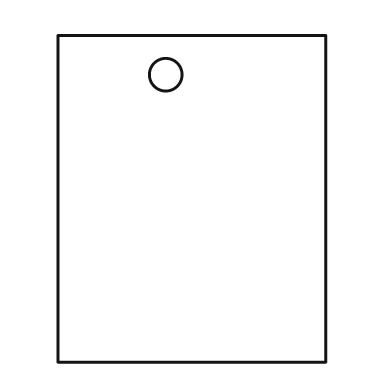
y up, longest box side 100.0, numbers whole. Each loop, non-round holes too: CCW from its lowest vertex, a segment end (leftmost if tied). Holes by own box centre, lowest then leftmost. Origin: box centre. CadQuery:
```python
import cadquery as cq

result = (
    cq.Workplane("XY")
    .moveTo(-41.0, -50.0)
    .lineTo(41.0, -50.0)
    .lineTo(41.0, 50.0)
    .lineTo(-41.0, 50.0)
    .close()
    .moveTo(-8.0, 38.0)
    .circle(5.0)
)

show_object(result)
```